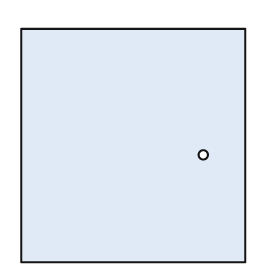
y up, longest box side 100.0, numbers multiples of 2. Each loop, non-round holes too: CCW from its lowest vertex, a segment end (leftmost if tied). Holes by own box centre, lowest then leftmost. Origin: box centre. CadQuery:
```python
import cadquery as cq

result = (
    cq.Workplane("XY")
    .moveTo(-48.0, -50.0)
    .lineTo(48.0, -50.0)
    .lineTo(48.0, 50.0)
    .lineTo(-48.0, 50.0)
    .close()
    .moveTo(30.0, -4.0)
    .circle(2.0)
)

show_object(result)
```